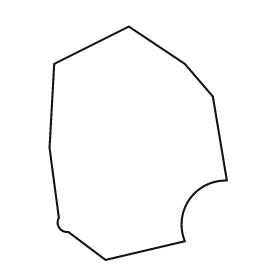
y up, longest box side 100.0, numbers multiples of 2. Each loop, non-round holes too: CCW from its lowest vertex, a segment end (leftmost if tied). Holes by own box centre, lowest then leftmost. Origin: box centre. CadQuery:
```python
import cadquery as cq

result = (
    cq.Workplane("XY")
    .moveTo(-14.0, -50.0)
    .lineTo(20.0, -42.0)
    .threePointArc((22.0, -24.0), (38.0, -16.0))
    .lineTo(32.0, 20.0)
    .lineTo(20.0, 34.0)
    .lineTo(-4.0, 50.0)
    .lineTo(-36.0, 34.0)
    .lineTo(-38.0, -2.0)
    .lineTo(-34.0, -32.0)
    .threePointArc((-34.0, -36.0), (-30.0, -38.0))
    .close()
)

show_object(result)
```